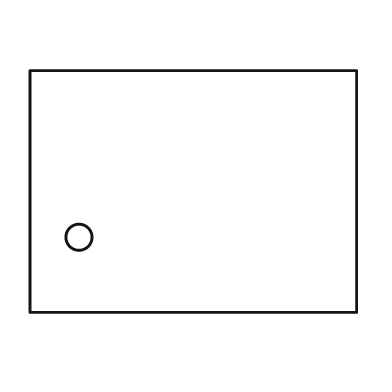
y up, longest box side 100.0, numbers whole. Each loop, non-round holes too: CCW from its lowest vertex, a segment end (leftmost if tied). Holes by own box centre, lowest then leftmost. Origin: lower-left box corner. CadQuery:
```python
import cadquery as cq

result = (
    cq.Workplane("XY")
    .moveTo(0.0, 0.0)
    .lineTo(100.0, 0.0)
    .lineTo(100.0, 74.0)
    .lineTo(0.0, 74.0)
    .close()
    .moveTo(15.0, 23.0)
    .circle(4.0)
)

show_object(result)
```